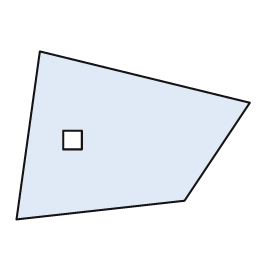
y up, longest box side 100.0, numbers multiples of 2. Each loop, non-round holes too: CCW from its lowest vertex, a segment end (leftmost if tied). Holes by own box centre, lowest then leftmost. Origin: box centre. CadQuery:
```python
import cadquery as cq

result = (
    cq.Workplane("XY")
    .moveTo(-50.0, -36.0)
    .lineTo(22.0, -28.0)
    .lineTo(50.0, 14.0)
    .lineTo(-40.0, 36.0)
    .close()
    .moveTo(-30.0, -6.0)
    .lineTo(-22.0, -6.0)
    .lineTo(-22.0, 2.0)
    .lineTo(-30.0, 2.0)
    .close()
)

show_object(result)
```